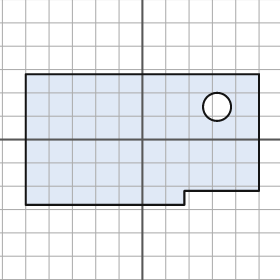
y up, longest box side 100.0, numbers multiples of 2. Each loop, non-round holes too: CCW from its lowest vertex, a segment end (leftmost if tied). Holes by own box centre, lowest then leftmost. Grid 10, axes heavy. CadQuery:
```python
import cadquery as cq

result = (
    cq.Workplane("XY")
    .moveTo(-50.0, -28.0)
    .lineTo(18.0, -28.0)
    .lineTo(18.0, -22.0)
    .lineTo(50.0, -22.0)
    .lineTo(50.0, 28.0)
    .lineTo(-50.0, 28.0)
    .close()
    .moveTo(32.0, 14.0)
    .circle(6.0)
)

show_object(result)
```